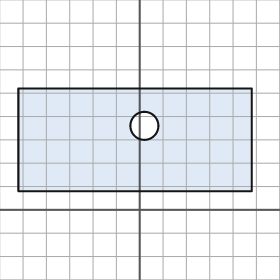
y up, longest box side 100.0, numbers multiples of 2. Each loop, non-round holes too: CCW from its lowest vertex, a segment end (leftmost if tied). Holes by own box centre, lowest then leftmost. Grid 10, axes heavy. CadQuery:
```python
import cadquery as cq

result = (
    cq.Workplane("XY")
    .moveTo(-52.0, 8.0)
    .lineTo(48.0, 8.0)
    .lineTo(48.0, 52.0)
    .lineTo(-52.0, 52.0)
    .close()
    .moveTo(2.0, 36.0)
    .circle(6.0)
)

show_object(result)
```